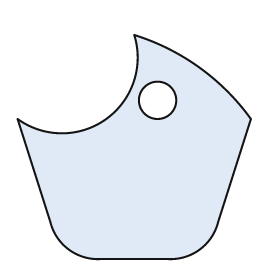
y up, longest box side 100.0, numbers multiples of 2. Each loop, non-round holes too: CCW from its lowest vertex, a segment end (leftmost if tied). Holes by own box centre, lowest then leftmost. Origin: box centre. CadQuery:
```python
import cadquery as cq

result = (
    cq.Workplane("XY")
    .moveTo(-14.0, -48.0)
    .lineTo(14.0, -48.0)
    .threePointArc((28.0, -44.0), (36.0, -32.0))
    .lineTo(50.0, 12.0)
    .threePointArc((28.0, 34.0), (0.0, 48.0))
    .threePointArc((-12.0, 12.0), (-50.0, 12.0))
    .lineTo(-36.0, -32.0)
    .threePointArc((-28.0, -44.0), (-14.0, -48.0))
    .close()
    .moveTo(10.0, 20.0)
    .circle(8.0)
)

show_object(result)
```